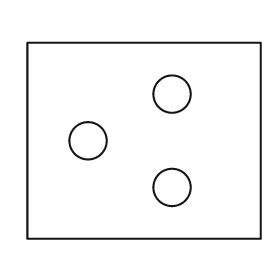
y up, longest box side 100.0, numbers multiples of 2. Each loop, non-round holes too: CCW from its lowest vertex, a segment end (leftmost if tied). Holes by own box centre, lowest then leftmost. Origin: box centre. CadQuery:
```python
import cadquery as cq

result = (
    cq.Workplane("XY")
    .moveTo(-50.0, -42.0)
    .lineTo(50.0, -42.0)
    .lineTo(50.0, 42.0)
    .lineTo(-50.0, 42.0)
    .close()
    .moveTo(12.0, -20.0)
    .circle(8.0)
    .moveTo(-24.0, 0.0)
    .circle(8.0)
    .moveTo(12.0, 20.0)
    .circle(8.0)
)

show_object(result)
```